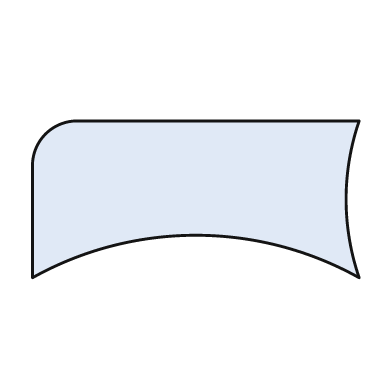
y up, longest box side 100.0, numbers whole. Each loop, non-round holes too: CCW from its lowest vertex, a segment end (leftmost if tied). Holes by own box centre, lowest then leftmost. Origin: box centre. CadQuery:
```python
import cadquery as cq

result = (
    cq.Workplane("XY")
    .moveTo(-50.0, -24.0)
    .threePointArc((0.0, -11.0), (50.0, -24.0))
    .threePointArc((46.0, 0.0), (50.0, 24.0))
    .lineTo(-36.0, 24.0)
    .threePointArc((-46.0, 20.0), (-50.0, 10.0))
    .close()
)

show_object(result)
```